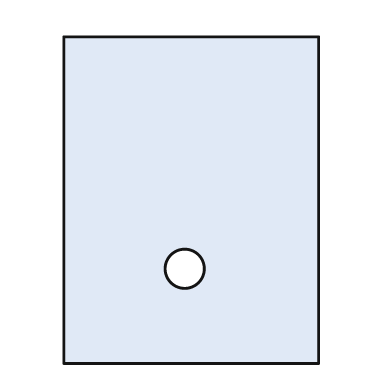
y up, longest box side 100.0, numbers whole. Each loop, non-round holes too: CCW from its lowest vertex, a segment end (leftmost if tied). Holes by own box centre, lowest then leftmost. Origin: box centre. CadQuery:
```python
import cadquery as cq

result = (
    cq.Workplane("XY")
    .moveTo(-39.0, -50.0)
    .lineTo(39.0, -50.0)
    .lineTo(39.0, 50.0)
    .lineTo(-39.0, 50.0)
    .close()
    .moveTo(-2.0, -21.0)
    .circle(6.0)
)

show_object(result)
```